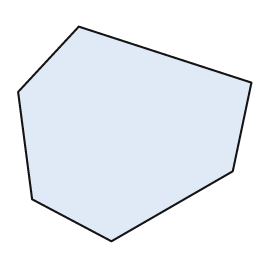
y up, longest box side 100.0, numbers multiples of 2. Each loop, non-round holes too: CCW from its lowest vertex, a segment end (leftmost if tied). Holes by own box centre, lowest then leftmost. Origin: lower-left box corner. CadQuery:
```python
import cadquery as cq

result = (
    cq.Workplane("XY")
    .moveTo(40.0, 0.0)
    .lineTo(92.0, 30.0)
    .lineTo(100.0, 68.0)
    .lineTo(26.0, 92.0)
    .lineTo(0.0, 64.0)
    .lineTo(6.0, 18.0)
    .close()
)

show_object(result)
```